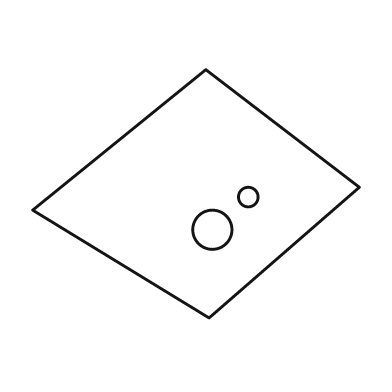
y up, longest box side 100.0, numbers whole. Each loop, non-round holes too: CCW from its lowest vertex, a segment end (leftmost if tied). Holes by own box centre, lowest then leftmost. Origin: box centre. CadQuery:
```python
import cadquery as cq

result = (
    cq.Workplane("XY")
    .moveTo(4.0, -38.0)
    .lineTo(50.0, 2.0)
    .lineTo(3.0, 38.0)
    .lineTo(-50.0, -5.0)
    .close()
    .moveTo(5.0, -11.0)
    .circle(6.0)
    .moveTo(16.0, -1.0)
    .circle(3.0)
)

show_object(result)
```